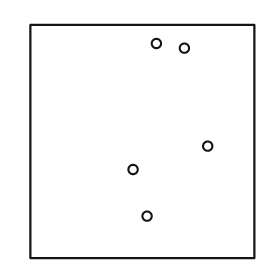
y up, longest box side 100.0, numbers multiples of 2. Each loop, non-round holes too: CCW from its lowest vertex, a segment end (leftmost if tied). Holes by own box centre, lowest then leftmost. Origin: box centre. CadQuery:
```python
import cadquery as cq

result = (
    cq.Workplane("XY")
    .moveTo(-48.0, -50.0)
    .lineTo(48.0, -50.0)
    .lineTo(48.0, 50.0)
    .lineTo(-48.0, 50.0)
    .close()
    .moveTo(2.0, -32.0)
    .circle(2.0)
    .moveTo(-4.0, -12.0)
    .circle(2.0)
    .moveTo(28.0, -2.0)
    .circle(2.0)
    .moveTo(18.0, 40.0)
    .circle(2.0)
    .moveTo(6.0, 42.0)
    .circle(2.0)
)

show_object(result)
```